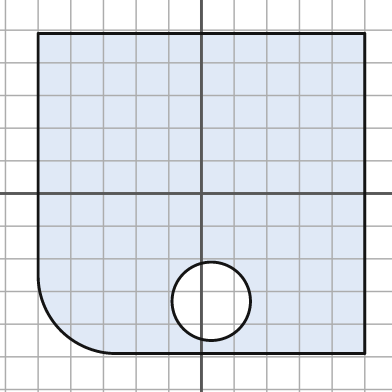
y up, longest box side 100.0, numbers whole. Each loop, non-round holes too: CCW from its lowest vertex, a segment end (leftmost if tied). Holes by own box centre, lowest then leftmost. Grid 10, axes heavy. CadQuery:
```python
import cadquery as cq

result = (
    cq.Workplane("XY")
    .moveTo(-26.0, -49.0)
    .lineTo(50.0, -49.0)
    .lineTo(50.0, 49.0)
    .lineTo(-50.0, 49.0)
    .lineTo(-50.0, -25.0)
    .threePointArc((-43.0, -42.0), (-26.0, -49.0))
    .close()
    .moveTo(3.0, -33.0)
    .circle(12.0)
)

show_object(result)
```